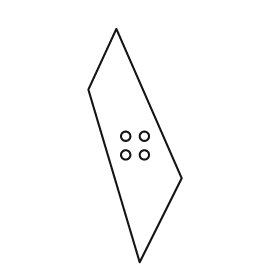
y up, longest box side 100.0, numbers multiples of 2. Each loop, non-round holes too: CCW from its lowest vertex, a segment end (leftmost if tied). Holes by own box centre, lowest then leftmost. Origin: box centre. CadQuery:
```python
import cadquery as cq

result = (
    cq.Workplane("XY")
    .moveTo(2.0, -50.0)
    .lineTo(20.0, -14.0)
    .lineTo(-8.0, 50.0)
    .lineTo(-20.0, 24.0)
    .close()
    .moveTo(-4.0, -4.0)
    .circle(2.0)
    .moveTo(4.0, -4.0)
    .circle(2.0)
    .moveTo(-4.0, 4.0)
    .circle(2.0)
    .moveTo(4.0, 4.0)
    .circle(2.0)
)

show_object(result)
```